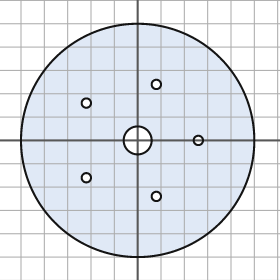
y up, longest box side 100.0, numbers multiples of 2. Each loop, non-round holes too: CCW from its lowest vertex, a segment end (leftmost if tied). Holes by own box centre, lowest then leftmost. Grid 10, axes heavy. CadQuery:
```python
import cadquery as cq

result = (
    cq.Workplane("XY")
    .moveTo(0.0, 0.0)
    .circle(50.0)
    .moveTo(8.0, -24.0)
    .circle(2.0)
    .moveTo(-22.0, -16.0)
    .circle(2.0)
    .moveTo(0.0, 0.0)
    .circle(6.0)
    .moveTo(26.0, 0.0)
    .circle(2.0)
    .moveTo(-22.0, 16.0)
    .circle(2.0)
    .moveTo(8.0, 24.0)
    .circle(2.0)
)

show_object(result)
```